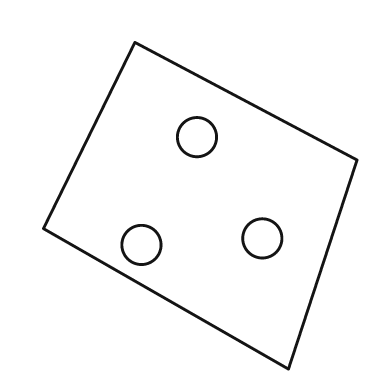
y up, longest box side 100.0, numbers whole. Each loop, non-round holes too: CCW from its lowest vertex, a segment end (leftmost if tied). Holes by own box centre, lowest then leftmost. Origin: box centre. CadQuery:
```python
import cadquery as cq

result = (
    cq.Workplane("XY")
    .moveTo(27.0, -50.0)
    .lineTo(48.0, 14.0)
    .lineTo(-20.0, 50.0)
    .lineTo(-48.0, -7.0)
    .close()
    .moveTo(-18.0, -12.0)
    .circle(6.0)
    .moveTo(19.0, -10.0)
    .circle(6.0)
    .moveTo(-1.0, 21.0)
    .circle(6.0)
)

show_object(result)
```